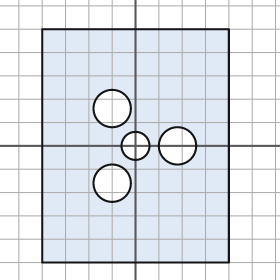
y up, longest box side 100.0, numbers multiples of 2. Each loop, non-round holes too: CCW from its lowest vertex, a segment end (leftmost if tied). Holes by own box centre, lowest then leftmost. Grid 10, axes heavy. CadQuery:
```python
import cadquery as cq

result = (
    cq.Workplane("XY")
    .moveTo(-40.0, -50.0)
    .lineTo(40.0, -50.0)
    .lineTo(40.0, 50.0)
    .lineTo(-40.0, 50.0)
    .close()
    .moveTo(-10.0, -16.0)
    .circle(8.0)
    .moveTo(0.0, 0.0)
    .circle(6.0)
    .moveTo(18.0, 0.0)
    .circle(8.0)
    .moveTo(-10.0, 16.0)
    .circle(8.0)
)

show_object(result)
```